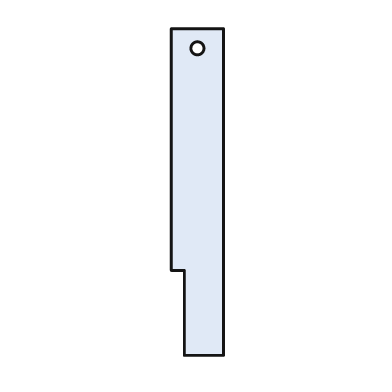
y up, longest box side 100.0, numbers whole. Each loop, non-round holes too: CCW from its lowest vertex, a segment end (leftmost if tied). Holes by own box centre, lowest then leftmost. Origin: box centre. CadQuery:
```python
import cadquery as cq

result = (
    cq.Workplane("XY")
    .moveTo(-4.0, -50.0)
    .lineTo(8.0, -50.0)
    .lineTo(8.0, 50.0)
    .lineTo(-8.0, 50.0)
    .lineTo(-8.0, -24.0)
    .lineTo(-4.0, -24.0)
    .close()
    .moveTo(0.0, 44.0)
    .circle(2.0)
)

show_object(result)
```